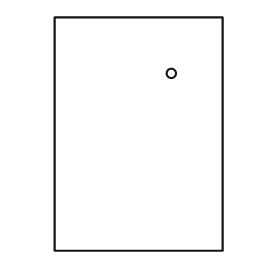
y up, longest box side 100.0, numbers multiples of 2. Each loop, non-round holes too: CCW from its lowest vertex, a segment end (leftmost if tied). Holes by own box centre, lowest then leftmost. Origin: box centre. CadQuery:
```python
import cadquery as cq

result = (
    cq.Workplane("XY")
    .moveTo(-36.0, -50.0)
    .lineTo(36.0, -50.0)
    .lineTo(36.0, 50.0)
    .lineTo(-36.0, 50.0)
    .close()
    .moveTo(14.0, 26.0)
    .circle(2.0)
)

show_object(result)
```